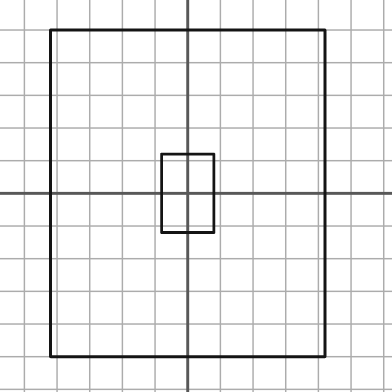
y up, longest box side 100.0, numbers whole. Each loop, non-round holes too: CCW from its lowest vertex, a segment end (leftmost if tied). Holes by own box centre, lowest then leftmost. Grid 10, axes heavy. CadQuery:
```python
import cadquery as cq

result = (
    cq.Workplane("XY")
    .moveTo(-42.0, -50.0)
    .lineTo(42.0, -50.0)
    .lineTo(42.0, 50.0)
    .lineTo(-42.0, 50.0)
    .close()
    .moveTo(-8.0, -12.0)
    .lineTo(8.0, -12.0)
    .lineTo(8.0, 12.0)
    .lineTo(-8.0, 12.0)
    .close()
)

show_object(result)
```